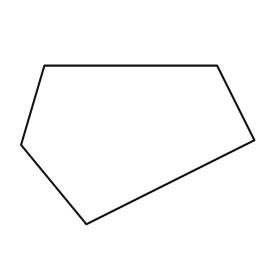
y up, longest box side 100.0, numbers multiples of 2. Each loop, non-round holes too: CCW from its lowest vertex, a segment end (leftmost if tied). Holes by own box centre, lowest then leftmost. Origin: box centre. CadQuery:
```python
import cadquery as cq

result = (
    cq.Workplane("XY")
    .moveTo(-22.0, -34.0)
    .lineTo(50.0, 2.0)
    .lineTo(34.0, 34.0)
    .lineTo(-40.0, 34.0)
    .lineTo(-50.0, 0.0)
    .close()
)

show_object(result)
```